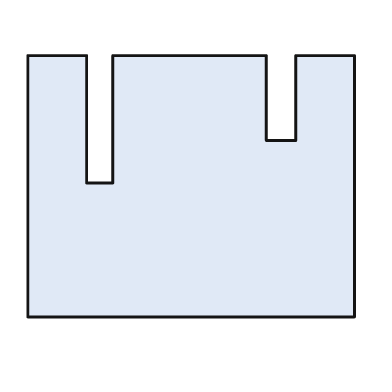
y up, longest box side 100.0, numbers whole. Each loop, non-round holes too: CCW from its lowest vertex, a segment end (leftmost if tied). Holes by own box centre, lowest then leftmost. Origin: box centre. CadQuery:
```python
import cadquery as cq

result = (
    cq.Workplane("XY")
    .moveTo(-50.0, -40.0)
    .lineTo(50.0, -40.0)
    .lineTo(50.0, 40.0)
    .lineTo(32.0, 40.0)
    .lineTo(32.0, 14.0)
    .lineTo(23.0, 14.0)
    .lineTo(23.0, 40.0)
    .lineTo(-24.0, 40.0)
    .lineTo(-24.0, 1.0)
    .lineTo(-32.0, 1.0)
    .lineTo(-32.0, 40.0)
    .lineTo(-50.0, 40.0)
    .close()
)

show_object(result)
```